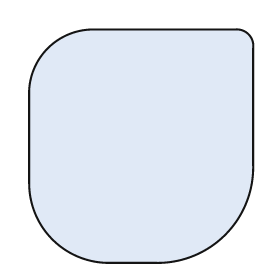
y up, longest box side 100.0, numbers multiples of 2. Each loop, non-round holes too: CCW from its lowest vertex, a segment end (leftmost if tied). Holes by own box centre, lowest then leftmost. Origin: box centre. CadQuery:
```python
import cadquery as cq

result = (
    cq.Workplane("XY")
    .moveTo(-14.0, -50.0)
    .lineTo(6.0, -50.0)
    .threePointArc((36.0, -38.0), (48.0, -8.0))
    .lineTo(48.0, 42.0)
    .threePointArc((46.0, 48.0), (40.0, 50.0))
    .lineTo(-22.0, 50.0)
    .threePointArc((-40.0, 42.0), (-48.0, 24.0))
    .lineTo(-48.0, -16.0)
    .threePointArc((-38.0, -40.0), (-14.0, -50.0))
    .close()
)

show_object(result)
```